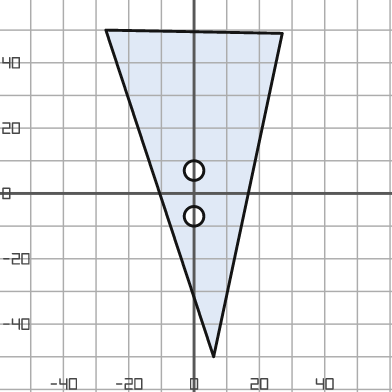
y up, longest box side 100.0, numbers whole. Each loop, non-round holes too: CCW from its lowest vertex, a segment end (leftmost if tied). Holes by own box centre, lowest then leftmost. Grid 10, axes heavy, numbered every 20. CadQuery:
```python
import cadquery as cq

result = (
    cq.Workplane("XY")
    .moveTo(6.0, -50.0)
    .lineTo(27.0, 49.0)
    .lineTo(-27.0, 50.0)
    .close()
    .moveTo(0.0, -7.0)
    .circle(3.0)
    .moveTo(0.0, 7.0)
    .circle(3.0)
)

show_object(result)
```